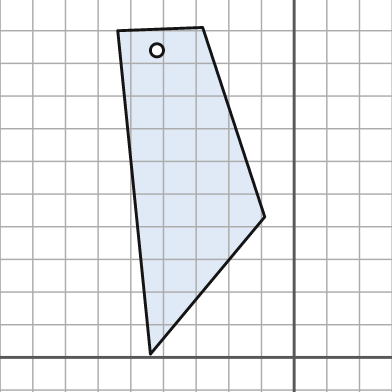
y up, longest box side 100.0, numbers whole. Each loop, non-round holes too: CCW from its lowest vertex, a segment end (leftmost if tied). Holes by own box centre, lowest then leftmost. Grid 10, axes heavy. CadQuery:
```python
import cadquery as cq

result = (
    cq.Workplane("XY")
    .moveTo(-44.0, 1.0)
    .lineTo(-9.0, 43.0)
    .lineTo(-28.0, 101.0)
    .lineTo(-54.0, 100.0)
    .close()
    .moveTo(-42.0, 94.0)
    .circle(2.0)
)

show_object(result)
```